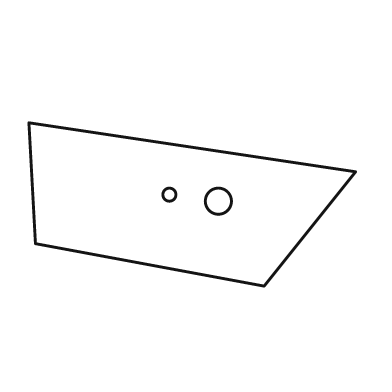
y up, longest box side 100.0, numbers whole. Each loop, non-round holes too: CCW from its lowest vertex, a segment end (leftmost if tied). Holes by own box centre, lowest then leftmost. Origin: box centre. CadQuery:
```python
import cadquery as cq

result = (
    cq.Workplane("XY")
    .moveTo(22.0, -25.0)
    .lineTo(50.0, 10.0)
    .lineTo(-50.0, 25.0)
    .lineTo(-48.0, -12.0)
    .close()
    .moveTo(8.0, 1.0)
    .circle(4.0)
    .moveTo(-7.0, 3.0)
    .circle(2.0)
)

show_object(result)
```